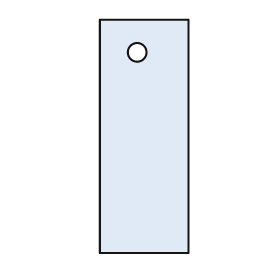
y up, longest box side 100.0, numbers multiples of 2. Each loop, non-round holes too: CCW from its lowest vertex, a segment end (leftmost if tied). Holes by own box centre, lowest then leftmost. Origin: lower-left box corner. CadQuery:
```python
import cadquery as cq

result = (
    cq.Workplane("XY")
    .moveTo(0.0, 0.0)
    .lineTo(38.0, 0.0)
    .lineTo(38.0, 100.0)
    .lineTo(0.0, 100.0)
    .close()
    .moveTo(16.0, 86.0)
    .circle(4.0)
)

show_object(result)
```